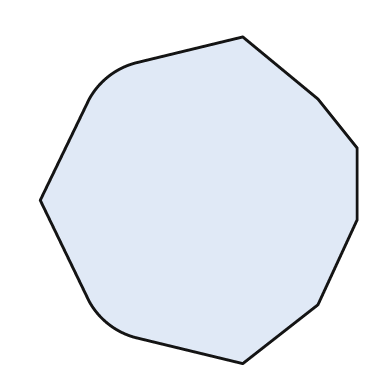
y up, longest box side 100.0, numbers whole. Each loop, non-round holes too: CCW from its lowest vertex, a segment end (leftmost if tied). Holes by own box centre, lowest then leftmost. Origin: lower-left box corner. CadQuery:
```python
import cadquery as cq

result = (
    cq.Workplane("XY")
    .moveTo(62.0, 0.0)
    .lineTo(85.0, 18.0)
    .lineTo(97.0, 44.0)
    .lineTo(97.0, 66.0)
    .lineTo(85.0, 81.0)
    .lineTo(62.0, 100.0)
    .lineTo(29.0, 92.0)
    .threePointArc((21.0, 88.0), (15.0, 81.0))
    .lineTo(0.0, 50.0)
    .lineTo(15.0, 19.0)
    .threePointArc((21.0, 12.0), (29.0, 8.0))
    .close()
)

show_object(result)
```